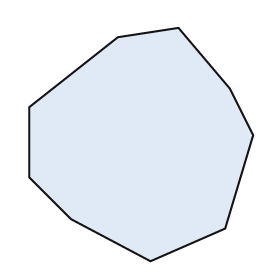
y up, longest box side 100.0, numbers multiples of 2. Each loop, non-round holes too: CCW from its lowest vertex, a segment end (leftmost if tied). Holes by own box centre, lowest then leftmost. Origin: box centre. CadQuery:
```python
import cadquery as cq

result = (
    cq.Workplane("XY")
    .moveTo(4.0, -50.0)
    .lineTo(36.0, -36.0)
    .lineTo(48.0, 4.0)
    .lineTo(38.0, 24.0)
    .lineTo(16.0, 50.0)
    .lineTo(-10.0, 46.0)
    .lineTo(-48.0, 16.0)
    .lineTo(-48.0, -14.0)
    .lineTo(-30.0, -32.0)
    .close()
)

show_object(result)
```